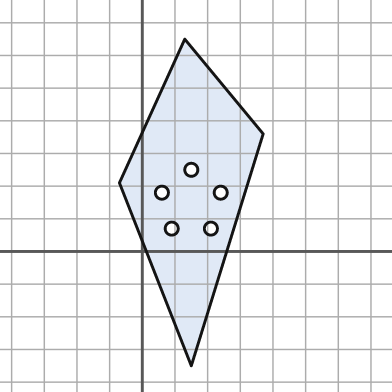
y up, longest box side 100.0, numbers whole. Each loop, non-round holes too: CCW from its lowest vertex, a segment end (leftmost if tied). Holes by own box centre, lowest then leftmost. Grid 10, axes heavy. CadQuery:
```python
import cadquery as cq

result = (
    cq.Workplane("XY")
    .moveTo(15.0, -35.0)
    .lineTo(37.0, 36.0)
    .lineTo(13.0, 65.0)
    .lineTo(-7.0, 21.0)
    .close()
    .moveTo(9.0, 7.0)
    .circle(2.0)
    .moveTo(21.0, 7.0)
    .circle(2.0)
    .moveTo(6.0, 18.0)
    .circle(2.0)
    .moveTo(24.0, 18.0)
    .circle(2.0)
    .moveTo(15.0, 25.0)
    .circle(2.0)
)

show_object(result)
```